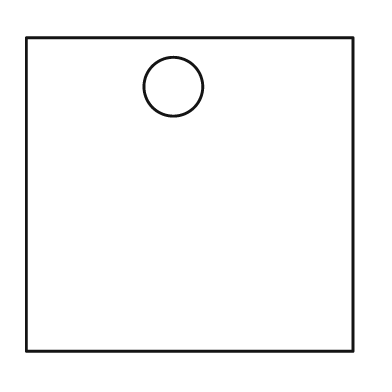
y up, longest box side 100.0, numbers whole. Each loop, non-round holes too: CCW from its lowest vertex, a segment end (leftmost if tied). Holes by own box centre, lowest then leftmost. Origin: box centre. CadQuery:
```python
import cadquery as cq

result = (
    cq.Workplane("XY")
    .moveTo(-50.0, -48.0)
    .lineTo(50.0, -48.0)
    .lineTo(50.0, 48.0)
    .lineTo(-50.0, 48.0)
    .close()
    .moveTo(-5.0, 33.0)
    .circle(9.0)
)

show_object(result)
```